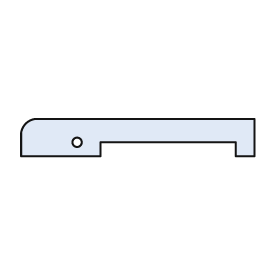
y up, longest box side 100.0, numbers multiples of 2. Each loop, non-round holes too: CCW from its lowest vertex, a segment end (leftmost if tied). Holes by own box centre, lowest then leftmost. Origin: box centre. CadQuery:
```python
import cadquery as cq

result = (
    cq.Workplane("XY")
    .moveTo(-50.0, -8.0)
    .lineTo(-16.0, -8.0)
    .lineTo(-16.0, -2.0)
    .lineTo(42.0, -2.0)
    .lineTo(42.0, -8.0)
    .lineTo(50.0, -8.0)
    .lineTo(50.0, 8.0)
    .lineTo(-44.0, 8.0)
    .threePointArc((-48.0, 6.0), (-50.0, 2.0))
    .close()
    .moveTo(-26.0, -2.0)
    .circle(2.0)
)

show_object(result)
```